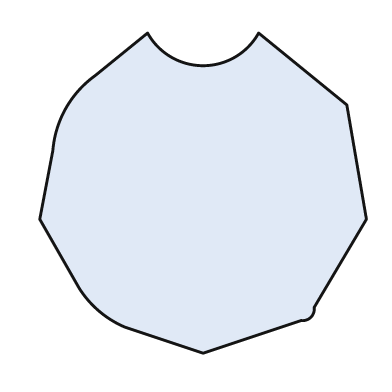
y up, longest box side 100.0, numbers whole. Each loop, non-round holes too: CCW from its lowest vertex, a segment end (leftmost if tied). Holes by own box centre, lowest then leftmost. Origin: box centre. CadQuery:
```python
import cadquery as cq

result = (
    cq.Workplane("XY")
    .moveTo(0.0, -49.0)
    .lineTo(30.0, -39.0)
    .threePointArc((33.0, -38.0), (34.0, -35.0))
    .lineTo(50.0, -8.0)
    .lineTo(44.0, 27.0)
    .lineTo(17.0, 49.0)
    .threePointArc((0.0, 39.0), (-17.0, 49.0))
    .lineTo(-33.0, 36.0)
    .threePointArc((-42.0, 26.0), (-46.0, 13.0))
    .lineTo(-50.0, -8.0)
    .lineTo(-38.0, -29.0)
    .threePointArc((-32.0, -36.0), (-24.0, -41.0))
    .close()
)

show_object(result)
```